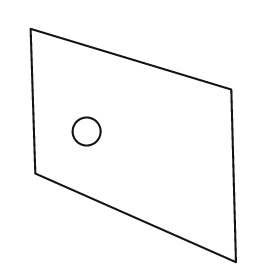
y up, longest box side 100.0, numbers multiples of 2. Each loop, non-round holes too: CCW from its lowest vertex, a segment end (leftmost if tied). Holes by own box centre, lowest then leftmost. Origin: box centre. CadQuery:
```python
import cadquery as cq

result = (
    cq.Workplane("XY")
    .moveTo(44.0, -50.0)
    .lineTo(42.0, 24.0)
    .lineTo(-44.0, 50.0)
    .lineTo(-42.0, -12.0)
    .close()
    .moveTo(-20.0, 6.0)
    .circle(6.0)
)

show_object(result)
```